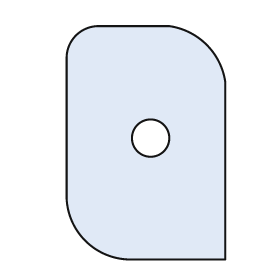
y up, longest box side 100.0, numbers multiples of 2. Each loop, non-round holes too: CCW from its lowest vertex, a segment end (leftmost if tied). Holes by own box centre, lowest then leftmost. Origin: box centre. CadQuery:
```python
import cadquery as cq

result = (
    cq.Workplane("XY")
    .moveTo(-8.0, -50.0)
    .lineTo(34.0, -50.0)
    .lineTo(34.0, 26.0)
    .threePointArc((26.0, 42.0), (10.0, 50.0))
    .lineTo(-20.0, 50.0)
    .threePointArc((-30.0, 46.0), (-34.0, 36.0))
    .lineTo(-34.0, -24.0)
    .threePointArc((-26.0, -42.0), (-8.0, -50.0))
    .close()
    .moveTo(2.0, 2.0)
    .circle(8.0)
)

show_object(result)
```